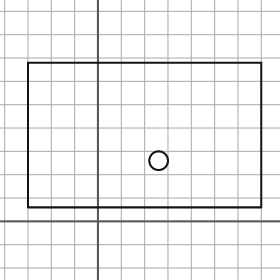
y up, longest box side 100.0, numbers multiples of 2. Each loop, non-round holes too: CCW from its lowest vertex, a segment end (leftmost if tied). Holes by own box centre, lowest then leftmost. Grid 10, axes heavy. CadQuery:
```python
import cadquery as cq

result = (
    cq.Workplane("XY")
    .moveTo(-30.0, 6.0)
    .lineTo(70.0, 6.0)
    .lineTo(70.0, 68.0)
    .lineTo(-30.0, 68.0)
    .close()
    .moveTo(26.0, 26.0)
    .circle(4.0)
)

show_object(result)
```